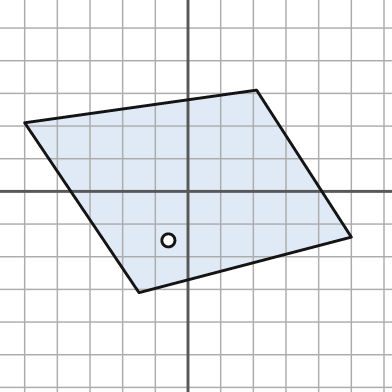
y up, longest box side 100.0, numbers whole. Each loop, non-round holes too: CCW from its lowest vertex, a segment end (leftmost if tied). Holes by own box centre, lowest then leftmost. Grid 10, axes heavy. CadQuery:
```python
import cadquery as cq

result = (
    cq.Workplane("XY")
    .moveTo(-15.0, -31.0)
    .lineTo(50.0, -14.0)
    .lineTo(21.0, 31.0)
    .lineTo(-50.0, 21.0)
    .close()
    .moveTo(-6.0, -15.0)
    .circle(2.0)
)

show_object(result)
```